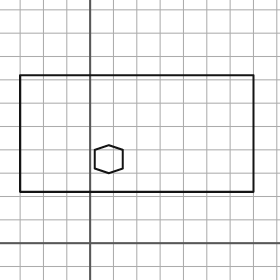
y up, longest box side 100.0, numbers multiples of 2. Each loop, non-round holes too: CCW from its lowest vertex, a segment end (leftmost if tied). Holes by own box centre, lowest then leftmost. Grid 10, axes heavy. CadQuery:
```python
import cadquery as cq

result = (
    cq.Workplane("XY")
    .moveTo(-30.0, 22.0)
    .lineTo(70.0, 22.0)
    .lineTo(70.0, 72.0)
    .lineTo(-30.0, 72.0)
    .close()
    .moveTo(8.0, 30.0)
    .lineTo(14.0, 32.0)
    .lineTo(14.0, 40.0)
    .lineTo(8.0, 42.0)
    .lineTo(2.0, 40.0)
    .lineTo(2.0, 32.0)
    .close()
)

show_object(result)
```